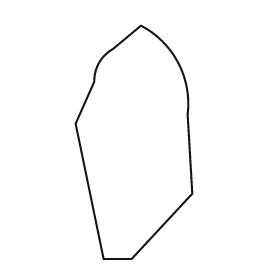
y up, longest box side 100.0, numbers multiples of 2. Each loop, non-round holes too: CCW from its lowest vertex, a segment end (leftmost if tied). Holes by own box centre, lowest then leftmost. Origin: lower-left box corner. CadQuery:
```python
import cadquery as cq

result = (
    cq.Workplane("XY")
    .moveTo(12.0, 0.0)
    .lineTo(24.0, 0.0)
    .lineTo(50.0, 28.0)
    .lineTo(48.0, 62.0)
    .threePointArc((44.0, 84.0), (28.0, 100.0))
    .lineTo(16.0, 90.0)
    .threePointArc((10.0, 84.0), (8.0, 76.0))
    .lineTo(0.0, 58.0)
    .close()
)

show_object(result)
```